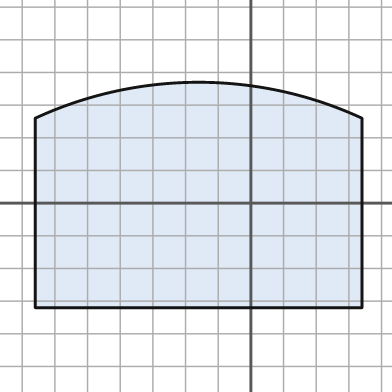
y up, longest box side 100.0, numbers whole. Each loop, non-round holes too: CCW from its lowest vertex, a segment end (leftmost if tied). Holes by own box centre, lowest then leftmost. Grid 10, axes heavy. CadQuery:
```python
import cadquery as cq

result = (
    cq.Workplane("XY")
    .moveTo(-66.0, -32.0)
    .lineTo(34.0, -32.0)
    .lineTo(34.0, 26.0)
    .threePointArc((-16.0, 37.0), (-66.0, 26.0))
    .close()
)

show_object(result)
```